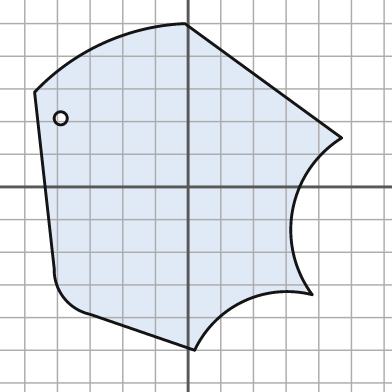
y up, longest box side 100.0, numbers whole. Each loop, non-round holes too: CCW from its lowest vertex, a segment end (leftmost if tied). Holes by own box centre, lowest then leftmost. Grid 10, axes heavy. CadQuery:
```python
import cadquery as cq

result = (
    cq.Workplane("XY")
    .moveTo(2.0, -50.0)
    .threePointArc((17.0, -35.0), (38.0, -33.0))
    .threePointArc((32.0, -7.0), (47.0, 15.0))
    .lineTo(-1.0, 50.0)
    .threePointArc((-26.0, 44.0), (-47.0, 29.0))
    .lineTo(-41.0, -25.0)
    .threePointArc((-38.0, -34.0), (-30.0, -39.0))
    .close()
    .moveTo(-39.0, 21.0)
    .circle(2.0)
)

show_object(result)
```